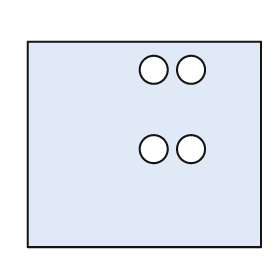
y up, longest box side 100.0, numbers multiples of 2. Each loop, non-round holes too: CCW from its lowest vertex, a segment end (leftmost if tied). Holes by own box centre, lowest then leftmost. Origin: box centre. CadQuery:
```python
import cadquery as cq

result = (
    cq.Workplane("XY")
    .moveTo(-50.0, -44.0)
    .lineTo(50.0, -44.0)
    .lineTo(50.0, 44.0)
    .lineTo(-50.0, 44.0)
    .close()
    .moveTo(4.0, -2.0)
    .circle(6.0)
    .moveTo(20.0, -2.0)
    .circle(6.0)
    .moveTo(4.0, 32.0)
    .circle(6.0)
    .moveTo(20.0, 32.0)
    .circle(6.0)
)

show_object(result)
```